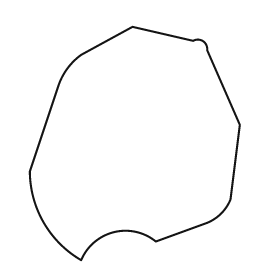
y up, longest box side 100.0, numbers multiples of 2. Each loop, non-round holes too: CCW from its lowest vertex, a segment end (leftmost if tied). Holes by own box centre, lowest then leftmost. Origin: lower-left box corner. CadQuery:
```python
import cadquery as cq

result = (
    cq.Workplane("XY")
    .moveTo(22.0, 0.0)
    .threePointArc((36.0, 12.0), (54.0, 8.0))
    .lineTo(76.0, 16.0)
    .threePointArc((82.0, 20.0), (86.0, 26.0))
    .lineTo(90.0, 58.0)
    .lineTo(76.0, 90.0)
    .threePointArc((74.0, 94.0), (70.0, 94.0))
    .lineTo(44.0, 100.0)
    .lineTo(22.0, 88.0)
    .threePointArc((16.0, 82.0), (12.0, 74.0))
    .lineTo(0.0, 38.0)
    .threePointArc((6.0, 16.0), (22.0, 0.0))
    .close()
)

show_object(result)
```